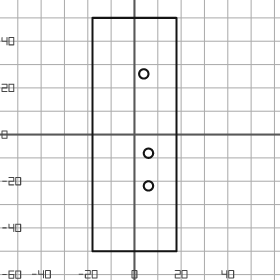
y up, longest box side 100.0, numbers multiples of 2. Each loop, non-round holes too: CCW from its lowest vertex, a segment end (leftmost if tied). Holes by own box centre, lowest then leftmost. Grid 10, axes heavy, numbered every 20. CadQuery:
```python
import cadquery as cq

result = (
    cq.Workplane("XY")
    .moveTo(-18.0, -50.0)
    .lineTo(18.0, -50.0)
    .lineTo(18.0, 50.0)
    .lineTo(-18.0, 50.0)
    .close()
    .moveTo(6.0, -22.0)
    .circle(2.0)
    .moveTo(6.0, -8.0)
    .circle(2.0)
    .moveTo(4.0, 26.0)
    .circle(2.0)
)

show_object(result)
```